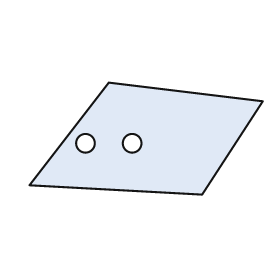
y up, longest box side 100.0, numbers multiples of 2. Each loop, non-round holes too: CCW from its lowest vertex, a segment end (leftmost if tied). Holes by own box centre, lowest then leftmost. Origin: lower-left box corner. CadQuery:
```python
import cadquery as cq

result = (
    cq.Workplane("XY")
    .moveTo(74.0, 0.0)
    .lineTo(100.0, 40.0)
    .lineTo(34.0, 48.0)
    .lineTo(0.0, 4.0)
    .close()
    .moveTo(24.0, 22.0)
    .circle(4.0)
    .moveTo(44.0, 22.0)
    .circle(4.0)
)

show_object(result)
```